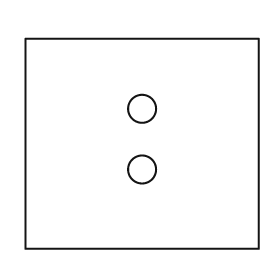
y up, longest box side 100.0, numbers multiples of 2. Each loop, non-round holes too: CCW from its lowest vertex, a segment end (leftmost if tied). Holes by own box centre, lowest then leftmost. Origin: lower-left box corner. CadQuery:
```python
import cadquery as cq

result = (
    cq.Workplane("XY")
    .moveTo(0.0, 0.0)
    .lineTo(100.0, 0.0)
    .lineTo(100.0, 90.0)
    .lineTo(0.0, 90.0)
    .close()
    .moveTo(50.0, 34.0)
    .circle(6.0)
    .moveTo(50.0, 60.0)
    .circle(6.0)
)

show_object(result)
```